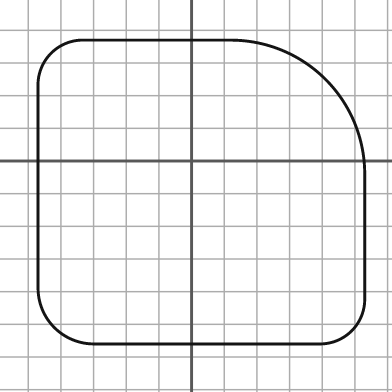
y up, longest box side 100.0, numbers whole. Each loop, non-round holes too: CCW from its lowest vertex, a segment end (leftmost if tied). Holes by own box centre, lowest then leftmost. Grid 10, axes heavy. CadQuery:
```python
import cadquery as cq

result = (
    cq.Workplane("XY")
    .moveTo(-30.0, -56.0)
    .lineTo(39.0, -56.0)
    .threePointArc((49.0, -52.0), (53.0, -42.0))
    .lineTo(53.0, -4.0)
    .threePointArc((41.0, 25.0), (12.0, 37.0))
    .lineTo(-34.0, 37.0)
    .threePointArc((-43.0, 33.0), (-47.0, 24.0))
    .lineTo(-47.0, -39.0)
    .threePointArc((-42.0, -51.0), (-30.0, -56.0))
    .close()
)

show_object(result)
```